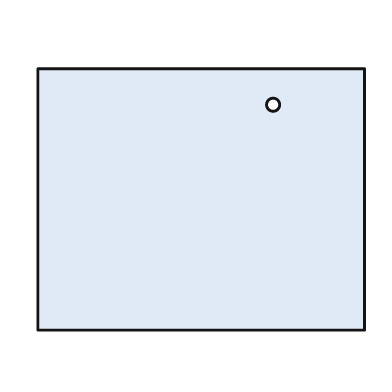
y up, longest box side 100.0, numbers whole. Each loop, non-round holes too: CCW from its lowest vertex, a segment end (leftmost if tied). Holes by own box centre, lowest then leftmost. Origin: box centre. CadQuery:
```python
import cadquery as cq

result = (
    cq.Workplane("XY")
    .moveTo(-50.0, -40.0)
    .lineTo(50.0, -40.0)
    .lineTo(50.0, 40.0)
    .lineTo(-50.0, 40.0)
    .close()
    .moveTo(22.0, 29.0)
    .circle(2.0)
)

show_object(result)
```